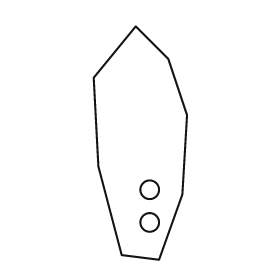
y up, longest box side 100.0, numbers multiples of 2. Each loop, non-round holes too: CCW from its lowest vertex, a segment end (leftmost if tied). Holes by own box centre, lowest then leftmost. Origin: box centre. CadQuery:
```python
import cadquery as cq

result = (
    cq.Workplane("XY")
    .moveTo(8.0, -50.0)
    .lineTo(18.0, -22.0)
    .lineTo(20.0, 12.0)
    .lineTo(12.0, 36.0)
    .lineTo(-2.0, 50.0)
    .lineTo(-20.0, 28.0)
    .lineTo(-18.0, -10.0)
    .lineTo(-8.0, -48.0)
    .close()
    .moveTo(4.0, -34.0)
    .circle(4.0)
    .moveTo(4.0, -20.0)
    .circle(4.0)
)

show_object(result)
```